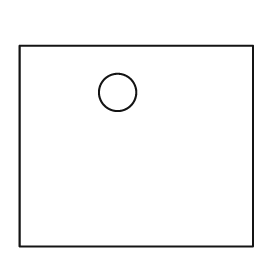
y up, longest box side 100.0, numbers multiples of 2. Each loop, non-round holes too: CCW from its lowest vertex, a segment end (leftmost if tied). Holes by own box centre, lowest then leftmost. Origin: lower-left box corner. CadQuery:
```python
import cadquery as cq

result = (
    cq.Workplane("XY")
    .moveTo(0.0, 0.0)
    .lineTo(100.0, 0.0)
    .lineTo(100.0, 86.0)
    .lineTo(0.0, 86.0)
    .close()
    .moveTo(42.0, 66.0)
    .circle(8.0)
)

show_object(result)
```